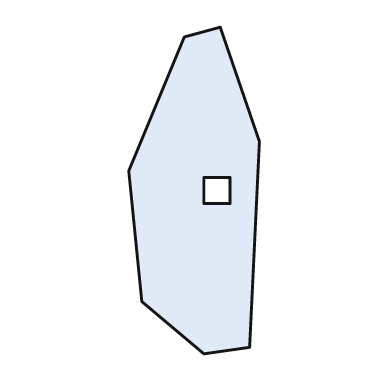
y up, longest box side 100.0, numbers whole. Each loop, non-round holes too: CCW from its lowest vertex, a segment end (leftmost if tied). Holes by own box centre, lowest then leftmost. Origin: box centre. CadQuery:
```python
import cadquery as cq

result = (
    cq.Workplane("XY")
    .moveTo(3.0, -50.0)
    .lineTo(17.0, -48.0)
    .lineTo(20.0, 15.0)
    .lineTo(8.0, 50.0)
    .lineTo(-3.0, 47.0)
    .lineTo(-20.0, 6.0)
    .lineTo(-16.0, -34.0)
    .close()
    .moveTo(3.0, -4.0)
    .lineTo(11.0, -4.0)
    .lineTo(11.0, 4.0)
    .lineTo(3.0, 4.0)
    .close()
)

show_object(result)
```